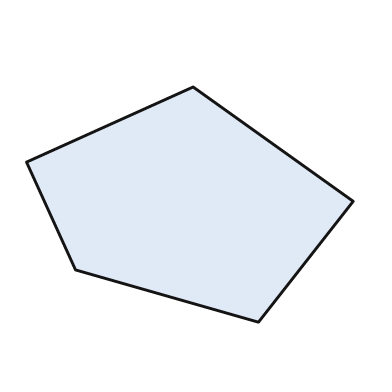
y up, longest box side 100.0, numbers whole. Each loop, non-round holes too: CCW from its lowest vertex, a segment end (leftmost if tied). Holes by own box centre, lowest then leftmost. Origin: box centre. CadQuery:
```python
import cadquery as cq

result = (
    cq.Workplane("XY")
    .moveTo(21.0, -36.0)
    .lineTo(50.0, 1.0)
    .lineTo(1.0, 36.0)
    .lineTo(-50.0, 13.0)
    .lineTo(-35.0, -20.0)
    .close()
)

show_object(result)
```